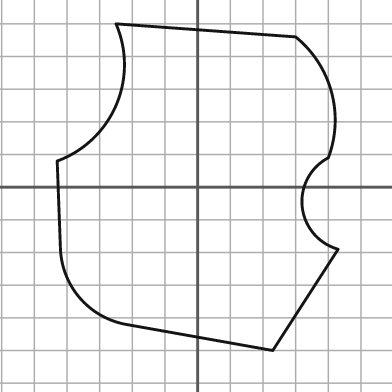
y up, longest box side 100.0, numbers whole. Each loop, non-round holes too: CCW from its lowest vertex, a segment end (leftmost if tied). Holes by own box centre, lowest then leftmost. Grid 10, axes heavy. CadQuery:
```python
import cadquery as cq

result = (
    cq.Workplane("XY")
    .moveTo(23.0, -50.0)
    .lineTo(43.0, -19.0)
    .threePointArc((32.0, -6.0), (40.0, 9.0))
    .threePointArc((41.0, 29.0), (30.0, 46.0))
    .lineTo(-25.0, 50.0)
    .threePointArc((-25.0, 25.0), (-43.0, 8.0))
    .lineTo(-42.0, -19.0)
    .threePointArc((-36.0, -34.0), (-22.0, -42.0))
    .close()
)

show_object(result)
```